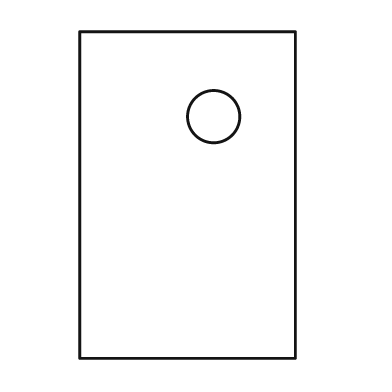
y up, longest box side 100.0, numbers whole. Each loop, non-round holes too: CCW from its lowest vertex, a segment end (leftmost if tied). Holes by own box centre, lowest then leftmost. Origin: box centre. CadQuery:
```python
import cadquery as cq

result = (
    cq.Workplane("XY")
    .moveTo(-33.0, -50.0)
    .lineTo(33.0, -50.0)
    .lineTo(33.0, 50.0)
    .lineTo(-33.0, 50.0)
    .close()
    .moveTo(8.0, 24.0)
    .circle(8.0)
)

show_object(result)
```